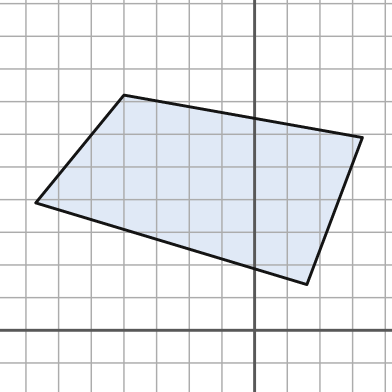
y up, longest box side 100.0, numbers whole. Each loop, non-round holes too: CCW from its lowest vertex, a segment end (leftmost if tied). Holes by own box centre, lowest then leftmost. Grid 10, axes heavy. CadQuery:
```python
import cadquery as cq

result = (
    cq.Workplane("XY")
    .moveTo(16.0, 14.0)
    .lineTo(33.0, 59.0)
    .lineTo(-40.0, 72.0)
    .lineTo(-67.0, 39.0)
    .close()
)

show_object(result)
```